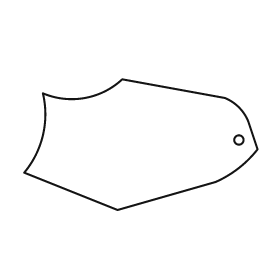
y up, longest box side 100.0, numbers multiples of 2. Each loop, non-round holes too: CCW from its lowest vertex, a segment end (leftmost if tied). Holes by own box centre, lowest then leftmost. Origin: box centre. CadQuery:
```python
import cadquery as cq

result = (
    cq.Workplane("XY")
    .moveTo(-10.0, -28.0)
    .lineTo(32.0, -16.0)
    .threePointArc((42.0, -10.0), (50.0, -2.0))
    .lineTo(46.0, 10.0)
    .threePointArc((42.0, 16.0), (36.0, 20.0))
    .lineTo(-8.0, 28.0)
    .threePointArc((-24.0, 20.0), (-42.0, 22.0))
    .threePointArc((-42.0, 4.0), (-50.0, -12.0))
    .close()
    .moveTo(42.0, 2.0)
    .circle(2.0)
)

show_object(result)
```